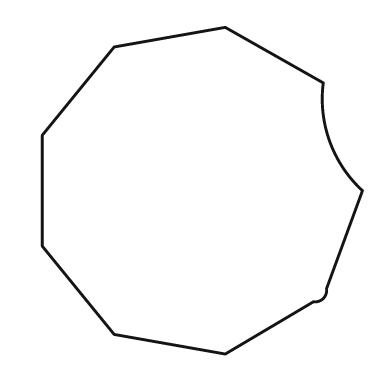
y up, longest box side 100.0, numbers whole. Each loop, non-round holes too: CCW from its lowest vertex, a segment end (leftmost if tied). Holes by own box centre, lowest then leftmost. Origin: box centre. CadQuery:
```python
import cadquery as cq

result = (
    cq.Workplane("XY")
    .moveTo(7.0, -50.0)
    .lineTo(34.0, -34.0)
    .threePointArc((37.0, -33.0), (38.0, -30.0))
    .lineTo(49.0, 0.0)
    .threePointArc((39.0, 15.0), (37.0, 33.0))
    .lineTo(7.0, 50.0)
    .lineTo(-27.0, 44.0)
    .lineTo(-49.0, 17.0)
    .lineTo(-49.0, -17.0)
    .lineTo(-27.0, -44.0)
    .close()
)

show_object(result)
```